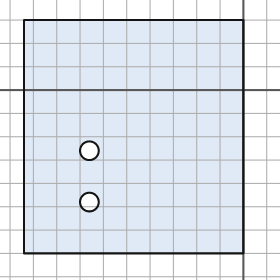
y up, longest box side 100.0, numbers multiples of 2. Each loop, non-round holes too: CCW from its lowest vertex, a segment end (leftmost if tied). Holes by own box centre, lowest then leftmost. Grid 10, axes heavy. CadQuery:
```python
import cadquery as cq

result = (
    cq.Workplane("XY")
    .moveTo(-94.0, -70.0)
    .lineTo(0.0, -70.0)
    .lineTo(0.0, 30.0)
    .lineTo(-94.0, 30.0)
    .close()
    .moveTo(-66.0, -48.0)
    .circle(4.0)
    .moveTo(-66.0, -26.0)
    .circle(4.0)
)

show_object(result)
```